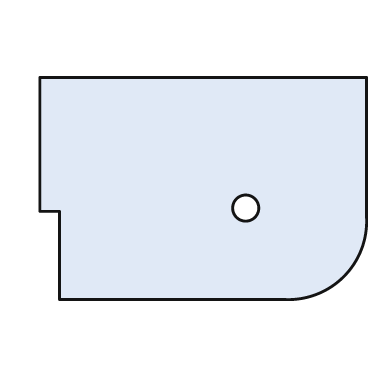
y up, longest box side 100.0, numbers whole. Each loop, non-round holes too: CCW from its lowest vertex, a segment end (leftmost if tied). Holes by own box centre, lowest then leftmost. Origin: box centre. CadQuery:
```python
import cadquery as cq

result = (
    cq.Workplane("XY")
    .moveTo(-44.0, -34.0)
    .lineTo(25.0, -34.0)
    .threePointArc((43.0, -27.0), (50.0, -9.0))
    .lineTo(50.0, 34.0)
    .lineTo(-50.0, 34.0)
    .lineTo(-50.0, -7.0)
    .lineTo(-44.0, -7.0)
    .close()
    .moveTo(13.0, -6.0)
    .circle(4.0)
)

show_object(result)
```